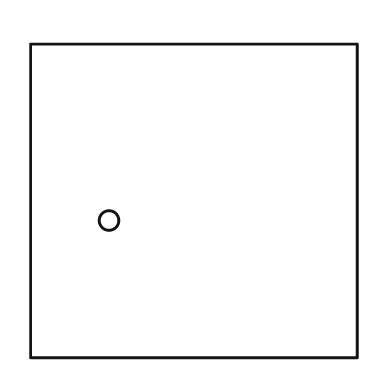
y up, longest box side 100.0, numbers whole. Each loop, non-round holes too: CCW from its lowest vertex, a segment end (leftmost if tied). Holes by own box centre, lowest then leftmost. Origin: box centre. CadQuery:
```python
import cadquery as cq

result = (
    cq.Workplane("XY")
    .moveTo(-50.0, -48.0)
    .lineTo(50.0, -48.0)
    .lineTo(50.0, 48.0)
    .lineTo(-50.0, 48.0)
    .close()
    .moveTo(-26.0, -6.0)
    .circle(3.0)
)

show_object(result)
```